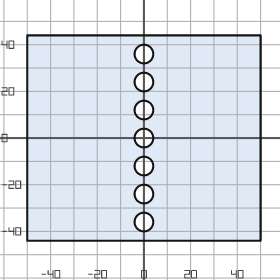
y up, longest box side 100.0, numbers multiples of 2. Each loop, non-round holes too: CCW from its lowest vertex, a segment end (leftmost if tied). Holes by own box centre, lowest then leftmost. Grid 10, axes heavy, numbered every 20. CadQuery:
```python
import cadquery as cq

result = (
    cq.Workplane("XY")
    .moveTo(-50.0, -44.0)
    .lineTo(50.0, -44.0)
    .lineTo(50.0, 44.0)
    .lineTo(-50.0, 44.0)
    .close()
    .moveTo(0.0, -36.0)
    .circle(4.0)
    .moveTo(0.0, -24.0)
    .circle(4.0)
    .moveTo(0.0, -12.0)
    .circle(4.0)
    .moveTo(0.0, 0.0)
    .circle(4.0)
    .moveTo(0.0, 12.0)
    .circle(4.0)
    .moveTo(0.0, 24.0)
    .circle(4.0)
    .moveTo(0.0, 36.0)
    .circle(4.0)
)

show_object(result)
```